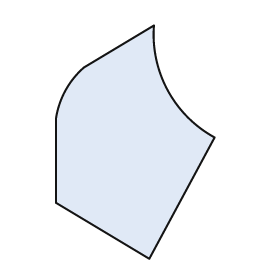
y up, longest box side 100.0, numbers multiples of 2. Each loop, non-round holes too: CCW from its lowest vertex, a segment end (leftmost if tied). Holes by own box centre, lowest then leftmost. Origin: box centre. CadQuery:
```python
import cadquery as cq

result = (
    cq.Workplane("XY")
    .moveTo(6.0, -50.0)
    .lineTo(34.0, 2.0)
    .threePointArc((14.0, 22.0), (8.0, 50.0))
    .lineTo(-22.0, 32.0)
    .threePointArc((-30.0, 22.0), (-34.0, 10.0))
    .lineTo(-34.0, -26.0)
    .close()
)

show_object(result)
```